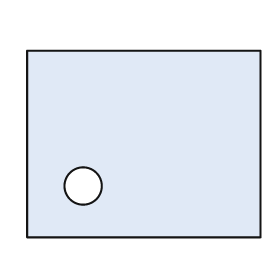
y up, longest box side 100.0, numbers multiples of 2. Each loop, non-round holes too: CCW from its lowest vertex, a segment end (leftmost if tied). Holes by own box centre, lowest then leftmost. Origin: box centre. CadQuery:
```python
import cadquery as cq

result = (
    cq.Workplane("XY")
    .moveTo(-50.0, -40.0)
    .lineTo(50.0, -40.0)
    .lineTo(50.0, 40.0)
    .lineTo(-50.0, 40.0)
    .close()
    .moveTo(-26.0, -18.0)
    .circle(8.0)
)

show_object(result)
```